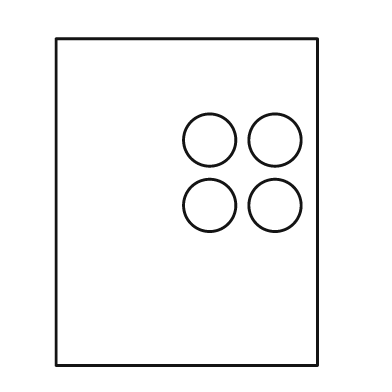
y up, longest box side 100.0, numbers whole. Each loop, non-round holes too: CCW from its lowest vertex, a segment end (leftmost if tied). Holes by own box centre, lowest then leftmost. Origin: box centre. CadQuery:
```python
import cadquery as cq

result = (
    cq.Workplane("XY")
    .moveTo(-40.0, -50.0)
    .lineTo(40.0, -50.0)
    .lineTo(40.0, 50.0)
    .lineTo(-40.0, 50.0)
    .close()
    .moveTo(7.0, -1.0)
    .circle(8.0)
    .moveTo(27.0, -1.0)
    .circle(8.0)
    .moveTo(7.0, 19.0)
    .circle(8.0)
    .moveTo(27.0, 19.0)
    .circle(8.0)
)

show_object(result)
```